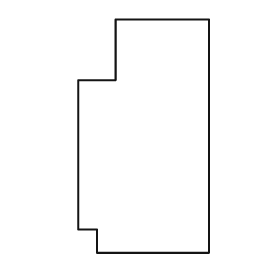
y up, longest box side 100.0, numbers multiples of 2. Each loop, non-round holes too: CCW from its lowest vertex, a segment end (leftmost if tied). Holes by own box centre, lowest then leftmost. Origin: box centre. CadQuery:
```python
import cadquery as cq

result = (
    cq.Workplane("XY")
    .moveTo(-20.0, -50.0)
    .lineTo(28.0, -50.0)
    .lineTo(28.0, 50.0)
    .lineTo(-12.0, 50.0)
    .lineTo(-12.0, 24.0)
    .lineTo(-28.0, 24.0)
    .lineTo(-28.0, -40.0)
    .lineTo(-20.0, -40.0)
    .close()
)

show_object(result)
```